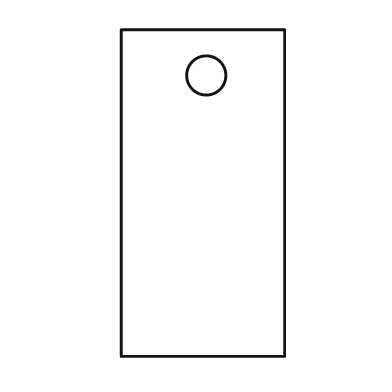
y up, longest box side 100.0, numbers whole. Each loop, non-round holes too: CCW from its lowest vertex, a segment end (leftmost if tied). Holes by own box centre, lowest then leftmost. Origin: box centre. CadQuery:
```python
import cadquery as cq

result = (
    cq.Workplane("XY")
    .moveTo(-25.0, -50.0)
    .lineTo(25.0, -50.0)
    .lineTo(25.0, 50.0)
    .lineTo(-25.0, 50.0)
    .close()
    .moveTo(1.0, 36.0)
    .circle(6.0)
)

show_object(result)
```